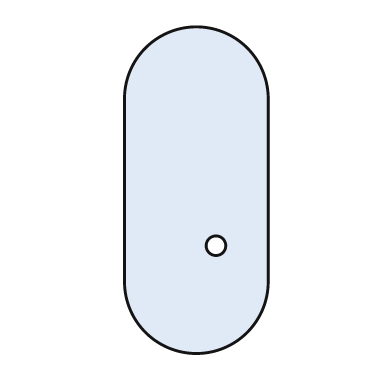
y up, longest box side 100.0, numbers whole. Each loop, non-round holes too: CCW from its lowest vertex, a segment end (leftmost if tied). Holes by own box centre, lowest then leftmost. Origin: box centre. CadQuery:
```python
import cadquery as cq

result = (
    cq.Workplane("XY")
    .moveTo(-22.0, -28.0)
    .threePointArc((0.0, -50.0), (22.0, -28.0))
    .lineTo(22.0, 28.0)
    .threePointArc((0.0, 50.0), (-22.0, 28.0))
    .close()
    .moveTo(6.0, -17.0)
    .circle(3.0)
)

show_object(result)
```